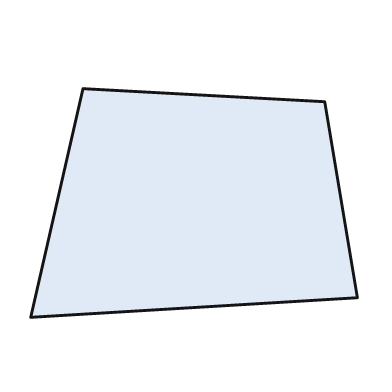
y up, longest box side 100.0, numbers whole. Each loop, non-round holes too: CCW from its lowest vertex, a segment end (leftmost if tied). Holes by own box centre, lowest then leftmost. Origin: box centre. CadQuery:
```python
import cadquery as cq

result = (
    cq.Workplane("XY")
    .moveTo(-50.0, -35.0)
    .lineTo(50.0, -29.0)
    .lineTo(40.0, 31.0)
    .lineTo(-34.0, 35.0)
    .close()
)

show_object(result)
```